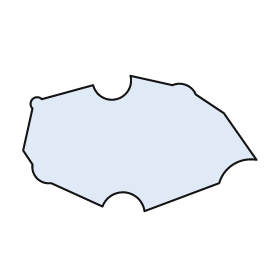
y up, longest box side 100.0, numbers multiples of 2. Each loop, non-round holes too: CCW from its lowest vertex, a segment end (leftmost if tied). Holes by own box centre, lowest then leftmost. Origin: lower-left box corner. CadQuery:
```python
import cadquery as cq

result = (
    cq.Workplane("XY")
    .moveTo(52.0, 0.0)
    .lineTo(84.0, 12.0)
    .threePointArc((90.0, 20.0), (100.0, 22.0))
    .lineTo(86.0, 42.0)
    .lineTo(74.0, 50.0)
    .threePointArc((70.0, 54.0), (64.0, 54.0))
    .lineTo(46.0, 58.0)
    .threePointArc((40.0, 48.0), (30.0, 54.0))
    .lineTo(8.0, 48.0)
    .threePointArc((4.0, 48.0), (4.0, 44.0))
    .lineTo(0.0, 26.0)
    .lineTo(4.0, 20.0)
    .threePointArc((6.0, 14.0), (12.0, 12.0))
    .lineTo(34.0, 2.0)
    .threePointArc((44.0, 8.0), (52.0, 0.0))
    .close()
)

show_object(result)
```